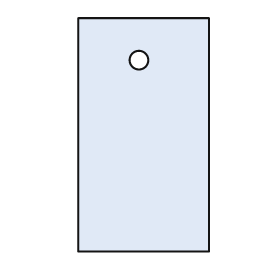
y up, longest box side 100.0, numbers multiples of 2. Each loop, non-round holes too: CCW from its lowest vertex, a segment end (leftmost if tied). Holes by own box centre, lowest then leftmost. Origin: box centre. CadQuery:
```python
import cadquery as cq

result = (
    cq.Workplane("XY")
    .moveTo(-28.0, -50.0)
    .lineTo(28.0, -50.0)
    .lineTo(28.0, 50.0)
    .lineTo(-28.0, 50.0)
    .close()
    .moveTo(-2.0, 32.0)
    .circle(4.0)
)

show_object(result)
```